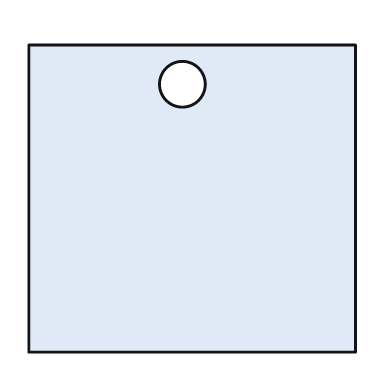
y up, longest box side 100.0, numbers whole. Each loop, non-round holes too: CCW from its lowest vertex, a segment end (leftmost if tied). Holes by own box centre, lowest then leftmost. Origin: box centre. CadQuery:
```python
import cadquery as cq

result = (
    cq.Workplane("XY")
    .moveTo(-50.0, -47.0)
    .lineTo(50.0, -47.0)
    .lineTo(50.0, 47.0)
    .lineTo(-50.0, 47.0)
    .close()
    .moveTo(-3.0, 35.0)
    .circle(7.0)
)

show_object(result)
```